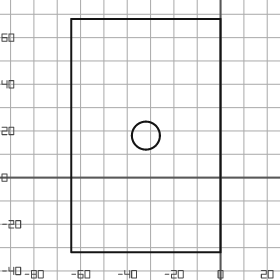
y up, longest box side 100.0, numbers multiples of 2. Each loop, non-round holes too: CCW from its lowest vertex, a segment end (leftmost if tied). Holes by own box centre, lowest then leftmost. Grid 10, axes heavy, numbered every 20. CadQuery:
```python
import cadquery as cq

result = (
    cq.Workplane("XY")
    .moveTo(-64.0, -32.0)
    .lineTo(0.0, -32.0)
    .lineTo(0.0, 68.0)
    .lineTo(-64.0, 68.0)
    .close()
    .moveTo(-32.0, 18.0)
    .circle(6.0)
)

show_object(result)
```